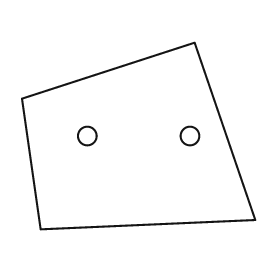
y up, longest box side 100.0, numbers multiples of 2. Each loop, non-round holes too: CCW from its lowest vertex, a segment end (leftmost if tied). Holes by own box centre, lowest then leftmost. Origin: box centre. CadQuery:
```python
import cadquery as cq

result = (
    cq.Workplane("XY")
    .moveTo(-42.0, -40.0)
    .lineTo(50.0, -36.0)
    .lineTo(24.0, 40.0)
    .lineTo(-50.0, 16.0)
    .close()
    .moveTo(-22.0, 0.0)
    .circle(4.0)
    .moveTo(22.0, 0.0)
    .circle(4.0)
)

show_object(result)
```